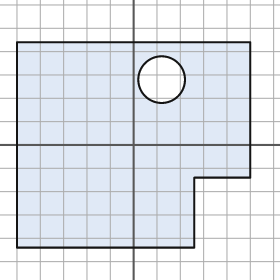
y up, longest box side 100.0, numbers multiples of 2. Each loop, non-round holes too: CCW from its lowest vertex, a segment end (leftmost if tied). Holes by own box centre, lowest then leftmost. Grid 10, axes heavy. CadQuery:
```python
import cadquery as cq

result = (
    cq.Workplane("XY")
    .moveTo(-50.0, -44.0)
    .lineTo(26.0, -44.0)
    .lineTo(26.0, -14.0)
    .lineTo(50.0, -14.0)
    .lineTo(50.0, 44.0)
    .lineTo(-50.0, 44.0)
    .close()
    .moveTo(12.0, 28.0)
    .circle(10.0)
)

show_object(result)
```